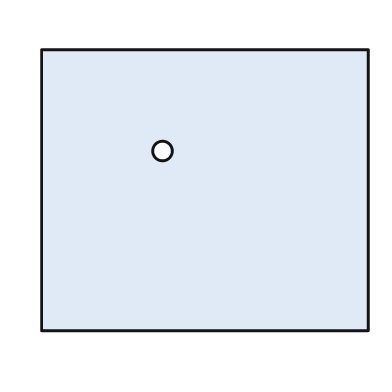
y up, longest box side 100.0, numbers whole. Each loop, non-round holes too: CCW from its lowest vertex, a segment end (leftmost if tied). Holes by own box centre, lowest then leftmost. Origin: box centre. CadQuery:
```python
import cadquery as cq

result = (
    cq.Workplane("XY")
    .moveTo(-50.0, -43.0)
    .lineTo(50.0, -43.0)
    .lineTo(50.0, 43.0)
    .lineTo(-50.0, 43.0)
    .close()
    .moveTo(-13.0, 12.0)
    .circle(3.0)
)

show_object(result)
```